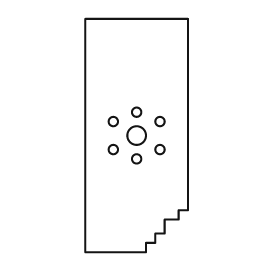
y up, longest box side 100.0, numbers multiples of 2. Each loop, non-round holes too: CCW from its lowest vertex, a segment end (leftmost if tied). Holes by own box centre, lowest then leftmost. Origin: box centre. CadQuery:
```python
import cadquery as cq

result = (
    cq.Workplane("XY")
    .moveTo(-22.0, -50.0)
    .lineTo(4.0, -50.0)
    .lineTo(4.0, -46.0)
    .lineTo(8.0, -46.0)
    .lineTo(8.0, -42.0)
    .lineTo(12.0, -42.0)
    .lineTo(12.0, -36.0)
    .lineTo(18.0, -36.0)
    .lineTo(18.0, -32.0)
    .lineTo(22.0, -32.0)
    .lineTo(22.0, 50.0)
    .lineTo(-22.0, 50.0)
    .close()
    .moveTo(0.0, -10.0)
    .circle(2.0)
    .moveTo(-10.0, -6.0)
    .circle(2.0)
    .moveTo(10.0, -6.0)
    .circle(2.0)
    .moveTo(0.0, 0.0)
    .circle(4.0)
    .moveTo(-10.0, 6.0)
    .circle(2.0)
    .moveTo(10.0, 6.0)
    .circle(2.0)
    .moveTo(0.0, 10.0)
    .circle(2.0)
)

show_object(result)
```